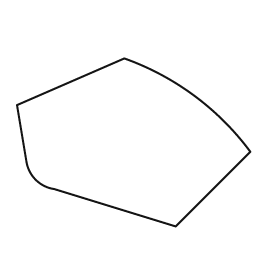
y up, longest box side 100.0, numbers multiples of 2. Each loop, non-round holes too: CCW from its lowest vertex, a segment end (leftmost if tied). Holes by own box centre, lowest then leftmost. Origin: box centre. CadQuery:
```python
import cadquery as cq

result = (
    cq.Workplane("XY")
    .moveTo(18.0, -36.0)
    .lineTo(50.0, -4.0)
    .threePointArc((26.0, 20.0), (-4.0, 36.0))
    .lineTo(-50.0, 16.0)
    .lineTo(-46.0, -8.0)
    .threePointArc((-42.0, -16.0), (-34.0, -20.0))
    .close()
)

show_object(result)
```